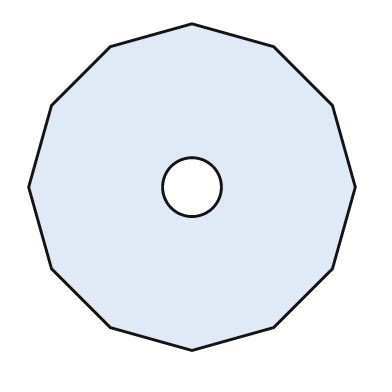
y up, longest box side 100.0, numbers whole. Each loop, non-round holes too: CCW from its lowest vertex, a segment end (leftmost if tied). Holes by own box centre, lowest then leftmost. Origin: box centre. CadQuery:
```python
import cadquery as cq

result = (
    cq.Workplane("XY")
    .moveTo(0.0, -50.0)
    .lineTo(25.0, -43.0)
    .lineTo(43.0, -25.0)
    .lineTo(50.0, 0.0)
    .lineTo(43.0, 25.0)
    .lineTo(25.0, 43.0)
    .lineTo(0.0, 50.0)
    .lineTo(-25.0, 43.0)
    .lineTo(-43.0, 25.0)
    .lineTo(-50.0, 0.0)
    .lineTo(-43.0, -25.0)
    .lineTo(-25.0, -43.0)
    .close()
    .moveTo(0.0, 0.0)
    .circle(9.0)
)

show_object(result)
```